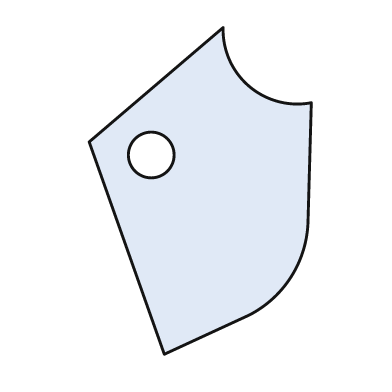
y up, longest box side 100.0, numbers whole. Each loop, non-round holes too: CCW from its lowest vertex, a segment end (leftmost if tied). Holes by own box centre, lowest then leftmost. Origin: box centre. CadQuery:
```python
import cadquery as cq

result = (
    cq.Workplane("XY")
    .moveTo(-11.0, -50.0)
    .lineTo(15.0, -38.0)
    .threePointArc((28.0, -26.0), (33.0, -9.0))
    .lineTo(34.0, 27.0)
    .threePointArc((15.0, 32.0), (7.0, 50.0))
    .lineTo(-34.0, 15.0)
    .close()
    .moveTo(-15.0, 11.0)
    .circle(7.0)
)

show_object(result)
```